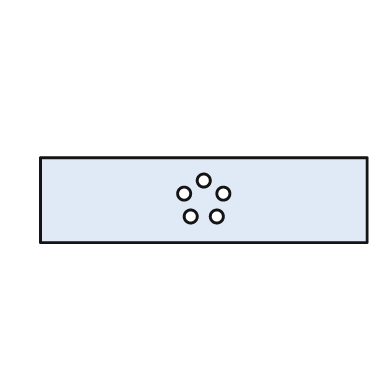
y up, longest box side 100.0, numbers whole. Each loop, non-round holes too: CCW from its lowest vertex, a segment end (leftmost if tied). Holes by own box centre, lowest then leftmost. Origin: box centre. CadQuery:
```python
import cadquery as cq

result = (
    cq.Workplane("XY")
    .moveTo(-50.0, -13.0)
    .lineTo(50.0, -13.0)
    .lineTo(50.0, 13.0)
    .lineTo(-50.0, 13.0)
    .close()
    .moveTo(-4.0, -5.0)
    .circle(2.0)
    .moveTo(4.0, -5.0)
    .circle(2.0)
    .moveTo(-6.0, 2.0)
    .circle(2.0)
    .moveTo(6.0, 2.0)
    .circle(2.0)
    .moveTo(0.0, 6.0)
    .circle(2.0)
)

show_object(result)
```